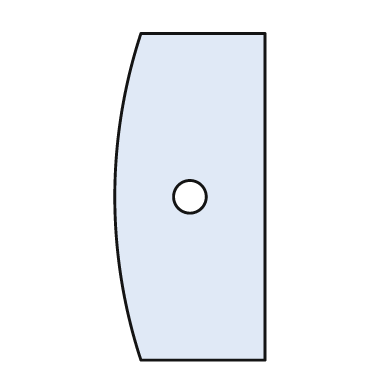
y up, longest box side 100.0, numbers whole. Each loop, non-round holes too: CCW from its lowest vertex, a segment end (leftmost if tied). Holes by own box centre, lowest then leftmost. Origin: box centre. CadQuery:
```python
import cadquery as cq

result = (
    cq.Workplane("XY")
    .moveTo(-15.0, -50.0)
    .lineTo(23.0, -50.0)
    .lineTo(23.0, 50.0)
    .lineTo(-15.0, 50.0)
    .threePointArc((-23.0, 0.0), (-15.0, -50.0))
    .close()
    .moveTo(0.0, 0.0)
    .circle(5.0)
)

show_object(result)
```